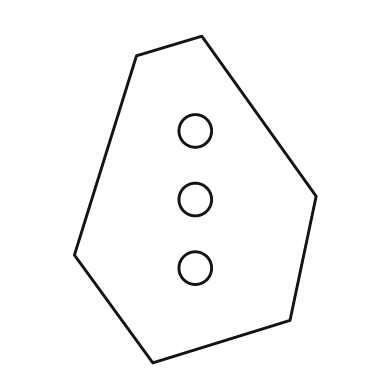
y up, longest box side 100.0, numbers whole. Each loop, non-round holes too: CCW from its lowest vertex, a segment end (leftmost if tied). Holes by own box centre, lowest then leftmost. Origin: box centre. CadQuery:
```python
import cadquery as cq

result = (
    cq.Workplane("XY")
    .moveTo(-13.0, -50.0)
    .lineTo(29.0, -37.0)
    .lineTo(37.0, 1.0)
    .lineTo(2.0, 50.0)
    .lineTo(-18.0, 44.0)
    .lineTo(-37.0, -17.0)
    .close()
    .moveTo(0.0, -21.0)
    .circle(5.0)
    .moveTo(0.0, 0.0)
    .circle(5.0)
    .moveTo(0.0, 21.0)
    .circle(5.0)
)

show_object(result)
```